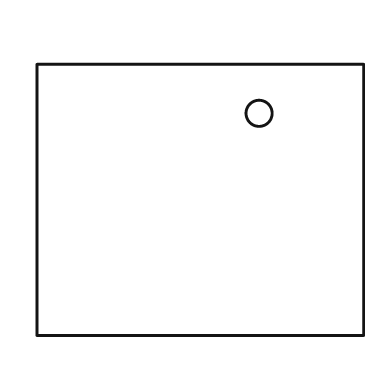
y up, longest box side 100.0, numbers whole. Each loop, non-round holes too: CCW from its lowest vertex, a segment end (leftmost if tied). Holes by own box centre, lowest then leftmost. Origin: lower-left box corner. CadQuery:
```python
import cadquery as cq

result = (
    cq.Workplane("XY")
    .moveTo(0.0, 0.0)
    .lineTo(100.0, 0.0)
    .lineTo(100.0, 83.0)
    .lineTo(0.0, 83.0)
    .close()
    .moveTo(68.0, 68.0)
    .circle(4.0)
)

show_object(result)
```